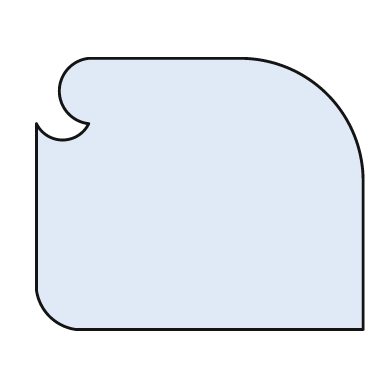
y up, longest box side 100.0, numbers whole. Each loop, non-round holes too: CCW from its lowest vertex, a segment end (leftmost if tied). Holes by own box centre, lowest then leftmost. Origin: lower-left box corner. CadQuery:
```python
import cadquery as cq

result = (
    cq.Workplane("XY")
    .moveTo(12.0, 0.0)
    .lineTo(100.0, 0.0)
    .lineTo(100.0, 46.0)
    .threePointArc((89.0, 72.0), (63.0, 83.0))
    .lineTo(16.0, 83.0)
    .threePointArc((7.0, 73.0), (16.0, 63.0))
    .threePointArc((8.0, 58.0), (0.0, 63.0))
    .lineTo(0.0, 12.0)
    .threePointArc((4.0, 4.0), (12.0, 0.0))
    .close()
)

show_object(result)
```